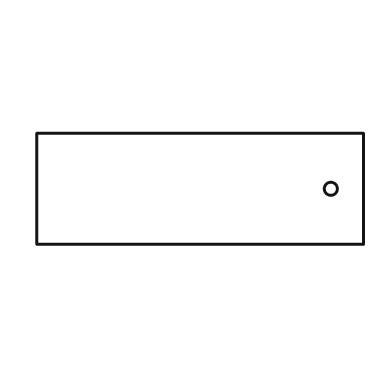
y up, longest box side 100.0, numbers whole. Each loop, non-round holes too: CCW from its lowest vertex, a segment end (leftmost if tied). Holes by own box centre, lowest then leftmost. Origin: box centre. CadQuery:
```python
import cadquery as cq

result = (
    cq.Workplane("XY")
    .moveTo(-50.0, -17.0)
    .lineTo(50.0, -17.0)
    .lineTo(50.0, 17.0)
    .lineTo(-50.0, 17.0)
    .close()
    .moveTo(40.0, 0.0)
    .circle(2.0)
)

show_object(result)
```